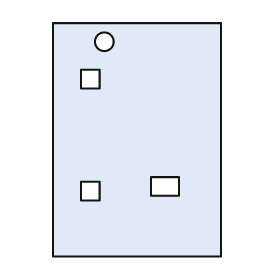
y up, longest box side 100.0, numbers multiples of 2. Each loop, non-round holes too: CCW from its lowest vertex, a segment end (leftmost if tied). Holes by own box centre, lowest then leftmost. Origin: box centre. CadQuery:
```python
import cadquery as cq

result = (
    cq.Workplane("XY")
    .moveTo(-36.0, -50.0)
    .lineTo(36.0, -50.0)
    .lineTo(36.0, 50.0)
    .lineTo(-36.0, 50.0)
    .close()
    .moveTo(-24.0, -26.0)
    .lineTo(-16.0, -26.0)
    .lineTo(-16.0, -18.0)
    .lineTo(-24.0, -18.0)
    .close()
    .moveTo(6.0, -24.0)
    .lineTo(18.0, -24.0)
    .lineTo(18.0, -16.0)
    .lineTo(6.0, -16.0)
    .close()
    .moveTo(-24.0, 22.0)
    .lineTo(-16.0, 22.0)
    .lineTo(-16.0, 30.0)
    .lineTo(-24.0, 30.0)
    .close()
    .moveTo(-14.0, 42.0)
    .circle(4.0)
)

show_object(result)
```